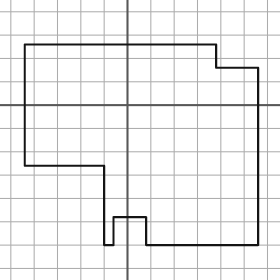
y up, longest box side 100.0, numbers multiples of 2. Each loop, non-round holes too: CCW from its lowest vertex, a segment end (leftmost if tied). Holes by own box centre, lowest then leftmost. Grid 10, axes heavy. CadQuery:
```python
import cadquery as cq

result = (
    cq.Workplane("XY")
    .moveTo(-10.0, -60.0)
    .lineTo(-6.0, -60.0)
    .lineTo(-6.0, -48.0)
    .lineTo(8.0, -48.0)
    .lineTo(8.0, -60.0)
    .lineTo(56.0, -60.0)
    .lineTo(56.0, 16.0)
    .lineTo(38.0, 16.0)
    .lineTo(38.0, 26.0)
    .lineTo(-44.0, 26.0)
    .lineTo(-44.0, -26.0)
    .lineTo(-10.0, -26.0)
    .close()
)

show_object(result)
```